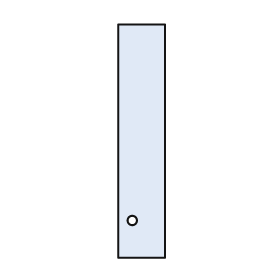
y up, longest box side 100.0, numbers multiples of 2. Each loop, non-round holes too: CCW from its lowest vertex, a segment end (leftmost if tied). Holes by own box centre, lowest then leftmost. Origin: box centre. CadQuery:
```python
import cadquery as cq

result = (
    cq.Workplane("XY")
    .moveTo(-10.0, -50.0)
    .lineTo(10.0, -50.0)
    .lineTo(10.0, 50.0)
    .lineTo(-10.0, 50.0)
    .close()
    .moveTo(-4.0, -34.0)
    .circle(2.0)
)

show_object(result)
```